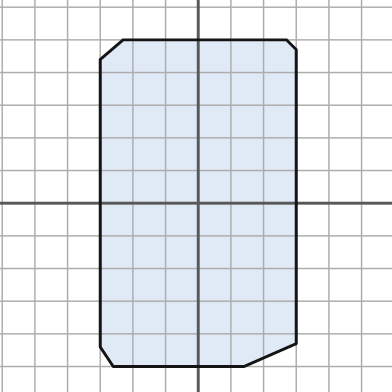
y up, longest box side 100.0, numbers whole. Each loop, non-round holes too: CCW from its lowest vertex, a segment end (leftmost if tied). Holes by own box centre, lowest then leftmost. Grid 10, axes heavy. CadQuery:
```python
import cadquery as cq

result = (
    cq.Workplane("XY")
    .moveTo(-26.0, -50.0)
    .lineTo(14.0, -50.0)
    .lineTo(30.0, -43.0)
    .lineTo(30.0, 47.0)
    .lineTo(27.0, 50.0)
    .lineTo(-23.0, 50.0)
    .lineTo(-30.0, 44.0)
    .lineTo(-30.0, -44.0)
    .close()
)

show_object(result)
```